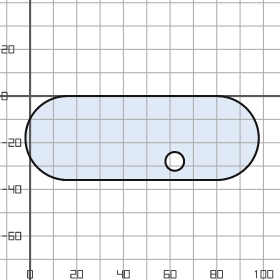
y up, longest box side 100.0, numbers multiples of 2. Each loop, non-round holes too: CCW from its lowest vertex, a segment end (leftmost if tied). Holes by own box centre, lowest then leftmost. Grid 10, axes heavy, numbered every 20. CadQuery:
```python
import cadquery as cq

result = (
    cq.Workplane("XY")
    .moveTo(16.0, -36.0)
    .lineTo(80.0, -36.0)
    .threePointArc((98.0, -18.0), (80.0, 0.0))
    .lineTo(16.0, 0.0)
    .threePointArc((-2.0, -18.0), (16.0, -36.0))
    .close()
    .moveTo(62.0, -28.0)
    .circle(4.0)
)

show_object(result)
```